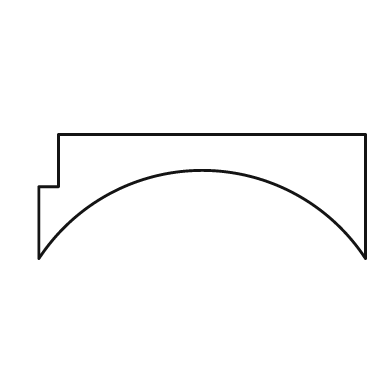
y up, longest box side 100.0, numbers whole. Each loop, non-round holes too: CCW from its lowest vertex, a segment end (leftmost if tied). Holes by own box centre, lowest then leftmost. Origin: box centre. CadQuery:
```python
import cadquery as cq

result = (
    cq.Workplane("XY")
    .moveTo(-50.0, -19.0)
    .threePointArc((0.0, 8.0), (50.0, -19.0))
    .lineTo(50.0, 19.0)
    .lineTo(-44.0, 19.0)
    .lineTo(-44.0, 3.0)
    .lineTo(-50.0, 3.0)
    .close()
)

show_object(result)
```